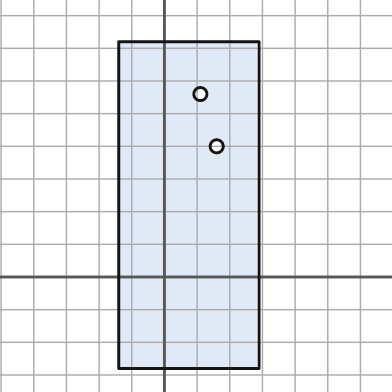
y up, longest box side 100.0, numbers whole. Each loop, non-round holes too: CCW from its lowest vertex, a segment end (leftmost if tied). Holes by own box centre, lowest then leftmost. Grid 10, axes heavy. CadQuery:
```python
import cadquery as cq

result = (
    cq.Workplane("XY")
    .moveTo(-14.0, -28.0)
    .lineTo(29.0, -28.0)
    .lineTo(29.0, 72.0)
    .lineTo(-14.0, 72.0)
    .close()
    .moveTo(16.0, 40.0)
    .circle(2.0)
    .moveTo(11.0, 56.0)
    .circle(2.0)
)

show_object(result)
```